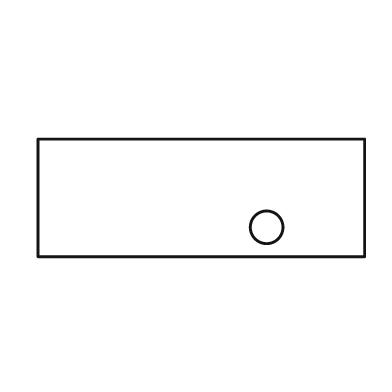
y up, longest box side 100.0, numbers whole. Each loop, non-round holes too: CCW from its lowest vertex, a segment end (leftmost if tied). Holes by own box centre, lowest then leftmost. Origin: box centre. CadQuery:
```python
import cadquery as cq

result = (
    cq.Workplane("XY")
    .moveTo(-50.0, -18.0)
    .lineTo(50.0, -18.0)
    .lineTo(50.0, 18.0)
    .lineTo(-50.0, 18.0)
    .close()
    .moveTo(20.0, -9.0)
    .circle(5.0)
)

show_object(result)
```